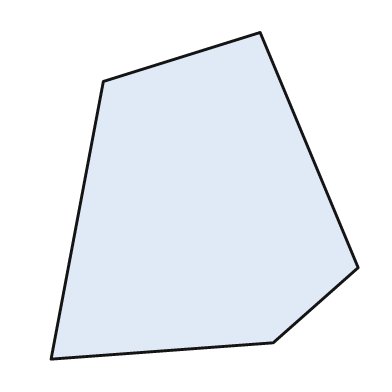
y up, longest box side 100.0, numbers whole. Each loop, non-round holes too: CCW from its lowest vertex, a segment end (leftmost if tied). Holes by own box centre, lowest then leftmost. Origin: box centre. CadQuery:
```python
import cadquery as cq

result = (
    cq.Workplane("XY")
    .moveTo(-47.0, -50.0)
    .lineTo(21.0, -45.0)
    .lineTo(47.0, -22.0)
    .lineTo(17.0, 50.0)
    .lineTo(-31.0, 35.0)
    .close()
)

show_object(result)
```